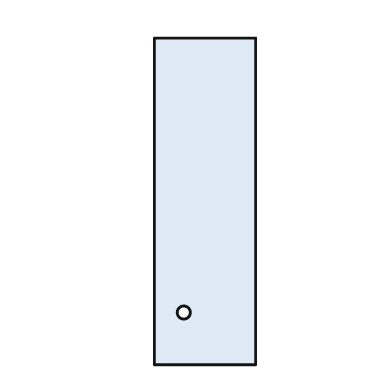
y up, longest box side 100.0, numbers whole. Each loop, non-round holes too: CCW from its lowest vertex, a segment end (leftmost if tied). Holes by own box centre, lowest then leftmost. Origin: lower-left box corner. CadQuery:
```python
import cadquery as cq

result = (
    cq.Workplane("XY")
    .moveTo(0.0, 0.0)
    .lineTo(31.0, 0.0)
    .lineTo(31.0, 100.0)
    .lineTo(0.0, 100.0)
    .close()
    .moveTo(9.0, 16.0)
    .circle(2.0)
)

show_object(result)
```